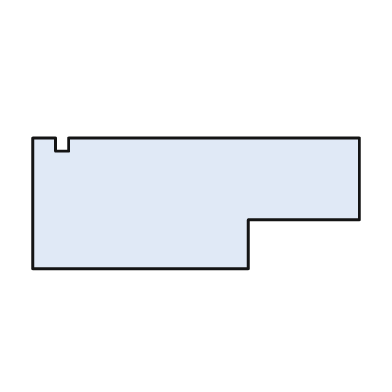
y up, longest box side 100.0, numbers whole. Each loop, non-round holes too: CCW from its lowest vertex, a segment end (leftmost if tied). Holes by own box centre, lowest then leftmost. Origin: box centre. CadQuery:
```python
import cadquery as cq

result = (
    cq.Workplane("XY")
    .moveTo(-50.0, -20.0)
    .lineTo(16.0, -20.0)
    .lineTo(16.0, -5.0)
    .lineTo(50.0, -5.0)
    .lineTo(50.0, 20.0)
    .lineTo(-39.0, 20.0)
    .lineTo(-39.0, 16.0)
    .lineTo(-43.0, 16.0)
    .lineTo(-43.0, 20.0)
    .lineTo(-50.0, 20.0)
    .close()
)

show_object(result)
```